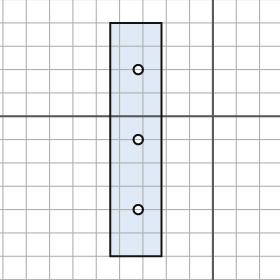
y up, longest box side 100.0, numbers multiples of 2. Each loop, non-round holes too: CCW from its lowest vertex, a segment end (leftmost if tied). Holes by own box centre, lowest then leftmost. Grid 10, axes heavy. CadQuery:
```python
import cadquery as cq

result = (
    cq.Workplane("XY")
    .moveTo(-44.0, -60.0)
    .lineTo(-22.0, -60.0)
    .lineTo(-22.0, 40.0)
    .lineTo(-44.0, 40.0)
    .close()
    .moveTo(-32.0, -40.0)
    .circle(2.0)
    .moveTo(-32.0, -10.0)
    .circle(2.0)
    .moveTo(-32.0, 20.0)
    .circle(2.0)
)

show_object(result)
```